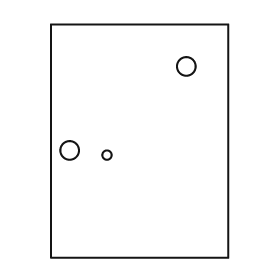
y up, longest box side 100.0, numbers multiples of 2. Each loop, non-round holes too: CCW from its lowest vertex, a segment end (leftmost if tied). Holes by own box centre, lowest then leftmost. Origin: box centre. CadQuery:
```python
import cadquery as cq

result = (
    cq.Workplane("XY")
    .moveTo(-38.0, -50.0)
    .lineTo(38.0, -50.0)
    .lineTo(38.0, 50.0)
    .lineTo(-38.0, 50.0)
    .close()
    .moveTo(-14.0, -6.0)
    .circle(2.0)
    .moveTo(-30.0, -4.0)
    .circle(4.0)
    .moveTo(20.0, 32.0)
    .circle(4.0)
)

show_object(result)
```